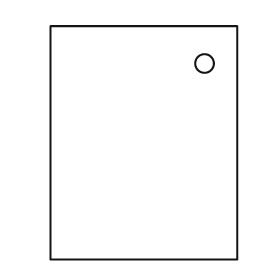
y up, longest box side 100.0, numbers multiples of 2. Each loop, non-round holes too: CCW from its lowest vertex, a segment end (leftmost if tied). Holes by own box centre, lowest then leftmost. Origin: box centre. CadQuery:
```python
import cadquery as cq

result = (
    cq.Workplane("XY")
    .moveTo(-40.0, -50.0)
    .lineTo(40.0, -50.0)
    .lineTo(40.0, 50.0)
    .lineTo(-40.0, 50.0)
    .close()
    .moveTo(26.0, 34.0)
    .circle(4.0)
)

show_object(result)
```